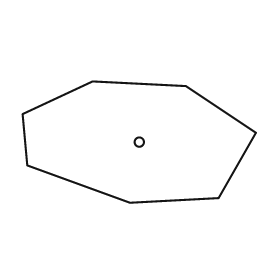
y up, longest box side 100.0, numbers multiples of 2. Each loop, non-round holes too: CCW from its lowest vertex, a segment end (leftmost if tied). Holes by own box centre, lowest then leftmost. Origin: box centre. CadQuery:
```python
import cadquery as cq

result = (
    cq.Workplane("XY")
    .moveTo(-4.0, -26.0)
    .lineTo(34.0, -24.0)
    .lineTo(50.0, 4.0)
    .lineTo(20.0, 24.0)
    .lineTo(-20.0, 26.0)
    .lineTo(-50.0, 12.0)
    .lineTo(-48.0, -10.0)
    .close()
    .moveTo(0.0, 0.0)
    .circle(2.0)
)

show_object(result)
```